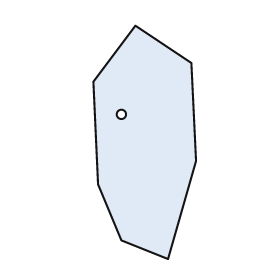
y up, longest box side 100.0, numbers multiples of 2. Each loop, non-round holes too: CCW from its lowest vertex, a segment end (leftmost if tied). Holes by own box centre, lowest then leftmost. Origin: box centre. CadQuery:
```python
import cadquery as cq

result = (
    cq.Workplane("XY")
    .moveTo(10.0, -50.0)
    .lineTo(22.0, -8.0)
    .lineTo(20.0, 34.0)
    .lineTo(-4.0, 50.0)
    .lineTo(-22.0, 26.0)
    .lineTo(-20.0, -18.0)
    .lineTo(-10.0, -42.0)
    .close()
    .moveTo(-10.0, 12.0)
    .circle(2.0)
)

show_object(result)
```